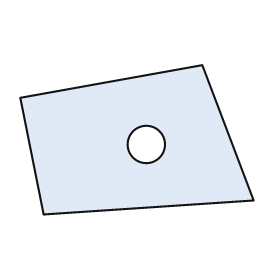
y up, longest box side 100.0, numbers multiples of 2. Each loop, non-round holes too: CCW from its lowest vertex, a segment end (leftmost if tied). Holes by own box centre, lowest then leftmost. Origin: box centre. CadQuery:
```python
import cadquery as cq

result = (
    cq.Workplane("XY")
    .moveTo(-40.0, -32.0)
    .lineTo(50.0, -26.0)
    .lineTo(28.0, 32.0)
    .lineTo(-50.0, 18.0)
    .close()
    .moveTo(4.0, -2.0)
    .circle(8.0)
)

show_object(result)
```